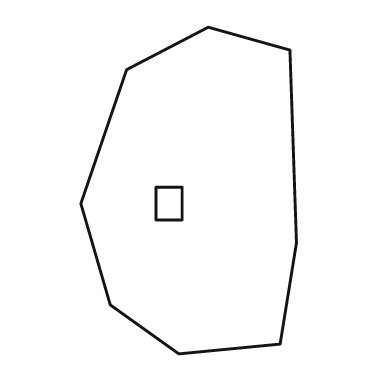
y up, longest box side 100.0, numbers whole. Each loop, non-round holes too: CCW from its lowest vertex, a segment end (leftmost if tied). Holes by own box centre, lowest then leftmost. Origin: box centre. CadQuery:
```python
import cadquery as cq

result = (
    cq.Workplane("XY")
    .moveTo(-3.0, -50.0)
    .lineTo(28.0, -47.0)
    .lineTo(33.0, -16.0)
    .lineTo(31.0, 43.0)
    .lineTo(6.0, 50.0)
    .lineTo(-19.0, 37.0)
    .lineTo(-33.0, -4.0)
    .lineTo(-24.0, -35.0)
    .close()
    .moveTo(-10.0, -9.0)
    .lineTo(-2.0, -9.0)
    .lineTo(-2.0, 1.0)
    .lineTo(-10.0, 1.0)
    .close()
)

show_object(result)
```